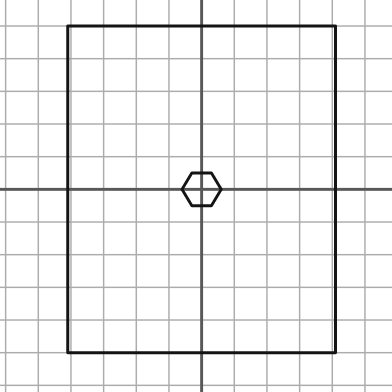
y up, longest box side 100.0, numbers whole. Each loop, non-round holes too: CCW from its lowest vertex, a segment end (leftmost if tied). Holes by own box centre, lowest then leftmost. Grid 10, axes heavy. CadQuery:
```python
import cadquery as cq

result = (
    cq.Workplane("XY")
    .moveTo(-41.0, -50.0)
    .lineTo(41.0, -50.0)
    .lineTo(41.0, 50.0)
    .lineTo(-41.0, 50.0)
    .close()
    .moveTo(-3.0, -5.0)
    .lineTo(3.0, -5.0)
    .lineTo(6.0, 0.0)
    .lineTo(3.0, 5.0)
    .lineTo(-3.0, 5.0)
    .lineTo(-6.0, 0.0)
    .close()
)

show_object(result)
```